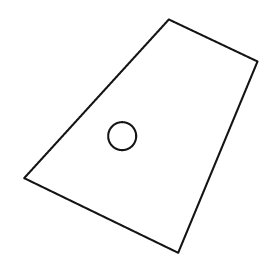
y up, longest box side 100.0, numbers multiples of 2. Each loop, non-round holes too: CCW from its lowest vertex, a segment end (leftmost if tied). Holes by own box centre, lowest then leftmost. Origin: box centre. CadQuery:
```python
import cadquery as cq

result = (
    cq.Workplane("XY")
    .moveTo(16.0, -50.0)
    .lineTo(50.0, 32.0)
    .lineTo(12.0, 50.0)
    .lineTo(-50.0, -18.0)
    .close()
    .moveTo(-8.0, 0.0)
    .circle(6.0)
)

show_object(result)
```